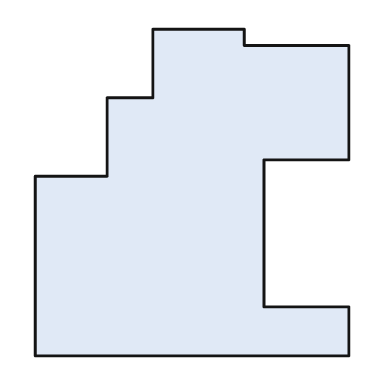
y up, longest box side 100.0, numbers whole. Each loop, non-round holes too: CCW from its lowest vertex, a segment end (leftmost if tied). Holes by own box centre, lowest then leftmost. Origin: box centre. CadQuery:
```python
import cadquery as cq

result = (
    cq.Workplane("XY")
    .moveTo(-48.0, -50.0)
    .lineTo(48.0, -50.0)
    .lineTo(48.0, -35.0)
    .lineTo(22.0, -35.0)
    .lineTo(22.0, 10.0)
    .lineTo(48.0, 10.0)
    .lineTo(48.0, 45.0)
    .lineTo(16.0, 45.0)
    .lineTo(16.0, 50.0)
    .lineTo(-12.0, 50.0)
    .lineTo(-12.0, 29.0)
    .lineTo(-26.0, 29.0)
    .lineTo(-26.0, 5.0)
    .lineTo(-48.0, 5.0)
    .close()
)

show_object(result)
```